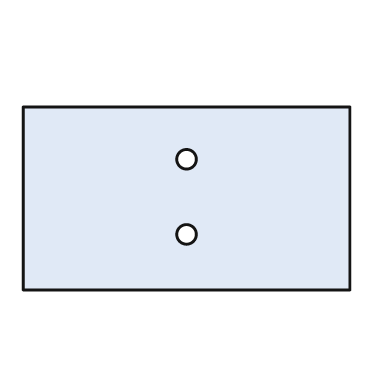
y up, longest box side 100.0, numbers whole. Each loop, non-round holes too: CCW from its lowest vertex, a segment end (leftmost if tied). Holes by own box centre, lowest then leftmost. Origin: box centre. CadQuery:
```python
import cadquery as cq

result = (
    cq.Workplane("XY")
    .moveTo(-50.0, -28.0)
    .lineTo(50.0, -28.0)
    .lineTo(50.0, 28.0)
    .lineTo(-50.0, 28.0)
    .close()
    .moveTo(0.0, -11.0)
    .circle(3.0)
    .moveTo(0.0, 12.0)
    .circle(3.0)
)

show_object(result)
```